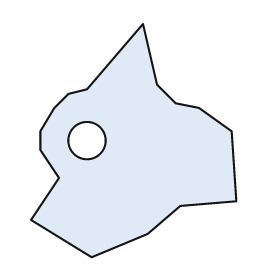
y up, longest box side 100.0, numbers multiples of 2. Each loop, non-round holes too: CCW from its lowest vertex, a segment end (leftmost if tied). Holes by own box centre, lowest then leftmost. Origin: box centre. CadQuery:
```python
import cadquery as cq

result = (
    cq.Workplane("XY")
    .moveTo(-18.0, -50.0)
    .lineTo(6.0, -40.0)
    .lineTo(20.0, -28.0)
    .lineTo(44.0, -26.0)
    .lineTo(42.0, 4.0)
    .lineTo(28.0, 14.0)
    .lineTo(18.0, 16.0)
    .lineTo(10.0, 24.0)
    .lineTo(4.0, 50.0)
    .lineTo(-20.0, 22.0)
    .lineTo(-28.0, 20.0)
    .lineTo(-34.0, 14.0)
    .lineTo(-40.0, 4.0)
    .lineTo(-40.0, -4.0)
    .lineTo(-32.0, -16.0)
    .lineTo(-44.0, -34.0)
    .close()
    .moveTo(-20.0, 0.0)
    .circle(8.0)
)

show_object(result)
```